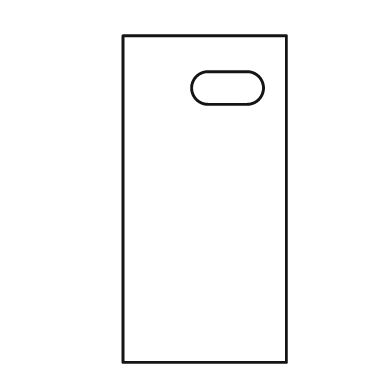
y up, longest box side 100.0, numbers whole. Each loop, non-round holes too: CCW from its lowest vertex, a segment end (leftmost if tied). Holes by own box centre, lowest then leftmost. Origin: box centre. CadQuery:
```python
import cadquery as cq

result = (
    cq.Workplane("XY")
    .moveTo(-25.0, -50.0)
    .lineTo(25.0, -50.0)
    .lineTo(25.0, 50.0)
    .lineTo(-25.0, 50.0)
    .close()
    .moveTo(1.0, 29.0)
    .lineTo(13.0, 29.0)
    .threePointArc((18.0, 34.0), (13.0, 39.0))
    .lineTo(1.0, 39.0)
    .threePointArc((-4.0, 34.0), (1.0, 29.0))
    .close()
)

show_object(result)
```